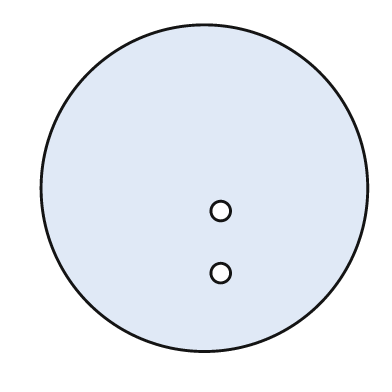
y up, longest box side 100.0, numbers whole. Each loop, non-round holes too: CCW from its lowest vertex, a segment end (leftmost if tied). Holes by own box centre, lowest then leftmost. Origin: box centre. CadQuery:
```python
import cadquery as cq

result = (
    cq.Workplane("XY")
    .moveTo(0.0, 0.0)
    .circle(50.0)
    .moveTo(5.0, -26.0)
    .circle(3.0)
    .moveTo(5.0, -7.0)
    .circle(3.0)
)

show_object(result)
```